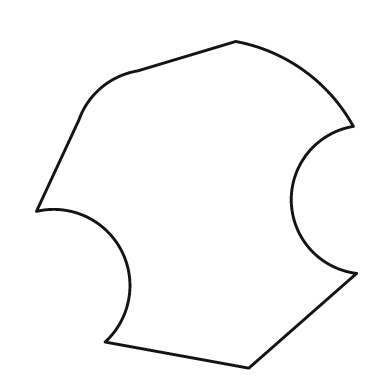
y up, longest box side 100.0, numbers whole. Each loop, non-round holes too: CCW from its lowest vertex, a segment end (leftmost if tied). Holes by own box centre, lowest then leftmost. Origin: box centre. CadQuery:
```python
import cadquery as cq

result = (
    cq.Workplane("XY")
    .moveTo(16.0, -50.0)
    .lineTo(49.0, -21.0)
    .threePointArc((29.0, 1.0), (48.0, 24.0))
    .threePointArc((33.0, 41.0), (12.0, 50.0))
    .lineTo(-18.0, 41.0)
    .threePointArc((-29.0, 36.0), (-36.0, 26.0))
    .lineTo(-49.0, -2.0)
    .threePointArc((-23.0, -14.0), (-28.0, -42.0))
    .close()
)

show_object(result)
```